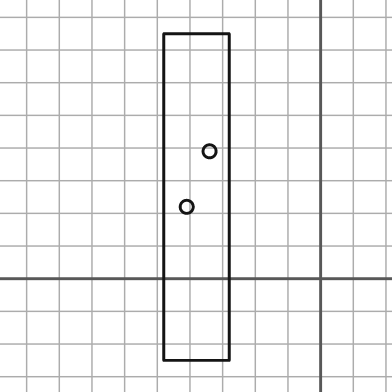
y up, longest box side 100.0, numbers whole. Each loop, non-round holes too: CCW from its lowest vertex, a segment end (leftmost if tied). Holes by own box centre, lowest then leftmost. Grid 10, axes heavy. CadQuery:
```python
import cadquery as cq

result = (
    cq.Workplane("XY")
    .moveTo(-48.0, -25.0)
    .lineTo(-28.0, -25.0)
    .lineTo(-28.0, 75.0)
    .lineTo(-48.0, 75.0)
    .close()
    .moveTo(-41.0, 22.0)
    .circle(2.0)
    .moveTo(-34.0, 39.0)
    .circle(2.0)
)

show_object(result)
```